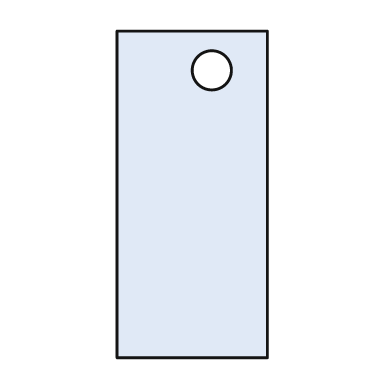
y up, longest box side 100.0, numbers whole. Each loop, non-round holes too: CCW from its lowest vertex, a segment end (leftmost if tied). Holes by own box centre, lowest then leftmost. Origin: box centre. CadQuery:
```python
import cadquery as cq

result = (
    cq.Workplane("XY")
    .moveTo(-23.0, -50.0)
    .lineTo(23.0, -50.0)
    .lineTo(23.0, 50.0)
    .lineTo(-23.0, 50.0)
    .close()
    .moveTo(6.0, 38.0)
    .circle(6.0)
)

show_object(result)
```